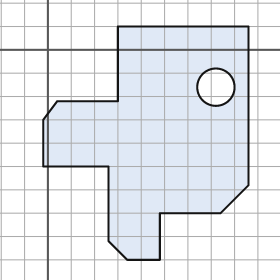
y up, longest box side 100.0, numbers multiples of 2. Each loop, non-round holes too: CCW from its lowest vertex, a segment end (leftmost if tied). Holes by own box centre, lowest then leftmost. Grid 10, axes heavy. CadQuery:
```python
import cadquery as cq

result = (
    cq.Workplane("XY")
    .moveTo(34.0, -90.0)
    .lineTo(48.0, -90.0)
    .lineTo(48.0, -70.0)
    .lineTo(74.0, -70.0)
    .lineTo(86.0, -58.0)
    .lineTo(86.0, 10.0)
    .lineTo(30.0, 10.0)
    .lineTo(30.0, -22.0)
    .lineTo(4.0, -22.0)
    .lineTo(-2.0, -30.0)
    .lineTo(-2.0, -50.0)
    .lineTo(26.0, -50.0)
    .lineTo(26.0, -82.0)
    .close()
    .moveTo(72.0, -16.0)
    .circle(8.0)
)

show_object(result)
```